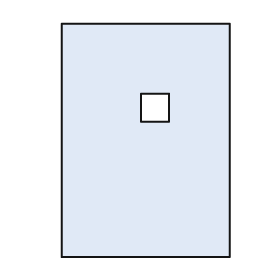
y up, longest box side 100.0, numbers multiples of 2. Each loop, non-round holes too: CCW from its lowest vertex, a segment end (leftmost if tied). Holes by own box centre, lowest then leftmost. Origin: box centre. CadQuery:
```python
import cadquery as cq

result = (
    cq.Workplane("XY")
    .moveTo(-36.0, -50.0)
    .lineTo(36.0, -50.0)
    .lineTo(36.0, 50.0)
    .lineTo(-36.0, 50.0)
    .close()
    .moveTo(-2.0, 8.0)
    .lineTo(10.0, 8.0)
    .lineTo(10.0, 20.0)
    .lineTo(-2.0, 20.0)
    .close()
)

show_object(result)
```